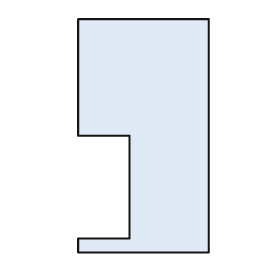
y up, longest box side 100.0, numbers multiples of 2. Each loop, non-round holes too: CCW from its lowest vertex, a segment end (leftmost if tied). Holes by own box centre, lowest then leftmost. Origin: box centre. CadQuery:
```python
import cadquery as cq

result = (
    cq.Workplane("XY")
    .moveTo(-28.0, -50.0)
    .lineTo(28.0, -50.0)
    .lineTo(28.0, 50.0)
    .lineTo(-28.0, 50.0)
    .lineTo(-28.0, 0.0)
    .lineTo(-6.0, 0.0)
    .lineTo(-6.0, -44.0)
    .lineTo(-28.0, -44.0)
    .close()
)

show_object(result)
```